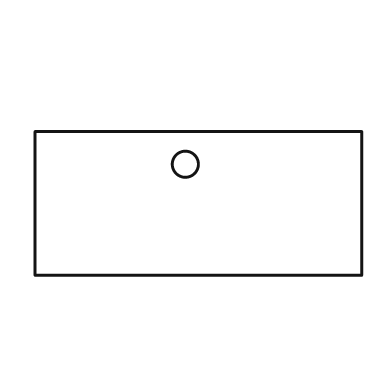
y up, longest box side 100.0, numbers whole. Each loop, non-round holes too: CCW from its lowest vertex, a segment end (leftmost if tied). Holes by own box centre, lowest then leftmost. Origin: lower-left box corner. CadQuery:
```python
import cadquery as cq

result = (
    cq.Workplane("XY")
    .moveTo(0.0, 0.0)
    .lineTo(100.0, 0.0)
    .lineTo(100.0, 44.0)
    .lineTo(0.0, 44.0)
    .close()
    .moveTo(46.0, 34.0)
    .circle(4.0)
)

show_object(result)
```